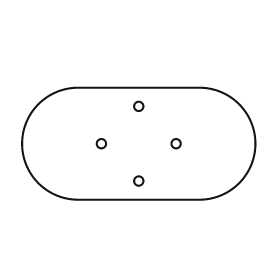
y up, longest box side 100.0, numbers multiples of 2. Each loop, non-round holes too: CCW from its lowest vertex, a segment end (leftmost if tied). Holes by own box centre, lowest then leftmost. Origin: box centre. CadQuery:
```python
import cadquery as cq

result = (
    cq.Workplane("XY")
    .moveTo(-26.0, -24.0)
    .lineTo(26.0, -24.0)
    .threePointArc((50.0, 0.0), (26.0, 24.0))
    .lineTo(-26.0, 24.0)
    .threePointArc((-50.0, 0.0), (-26.0, -24.0))
    .close()
    .moveTo(0.0, -16.0)
    .circle(2.0)
    .moveTo(-16.0, 0.0)
    .circle(2.0)
    .moveTo(16.0, 0.0)
    .circle(2.0)
    .moveTo(0.0, 16.0)
    .circle(2.0)
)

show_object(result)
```